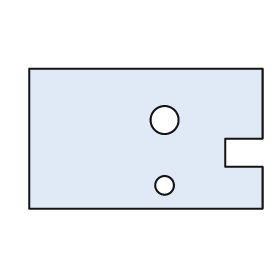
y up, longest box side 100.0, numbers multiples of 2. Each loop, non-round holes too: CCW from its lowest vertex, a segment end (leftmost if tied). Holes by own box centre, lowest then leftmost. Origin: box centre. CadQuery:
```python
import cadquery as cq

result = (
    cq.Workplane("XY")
    .moveTo(-50.0, -30.0)
    .lineTo(50.0, -30.0)
    .lineTo(50.0, -12.0)
    .lineTo(34.0, -12.0)
    .lineTo(34.0, 0.0)
    .lineTo(50.0, 0.0)
    .lineTo(50.0, 30.0)
    .lineTo(-50.0, 30.0)
    .close()
    .moveTo(8.0, -20.0)
    .circle(4.0)
    .moveTo(8.0, 8.0)
    .circle(6.0)
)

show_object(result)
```